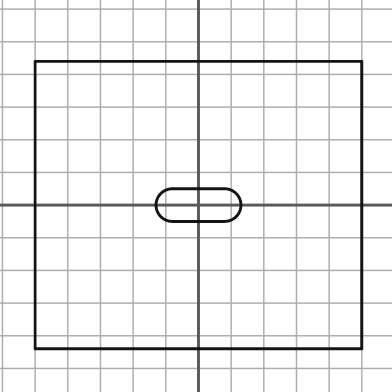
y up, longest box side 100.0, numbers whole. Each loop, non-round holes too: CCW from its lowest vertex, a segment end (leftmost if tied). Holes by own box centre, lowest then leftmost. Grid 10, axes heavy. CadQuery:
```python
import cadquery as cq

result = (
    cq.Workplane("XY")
    .moveTo(-50.0, -44.0)
    .lineTo(50.0, -44.0)
    .lineTo(50.0, 44.0)
    .lineTo(-50.0, 44.0)
    .close()
    .moveTo(-8.0, -5.0)
    .lineTo(8.0, -5.0)
    .threePointArc((13.0, 0.0), (8.0, 5.0))
    .lineTo(-8.0, 5.0)
    .threePointArc((-13.0, 0.0), (-8.0, -5.0))
    .close()
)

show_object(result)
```